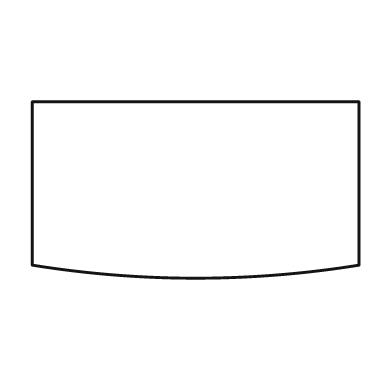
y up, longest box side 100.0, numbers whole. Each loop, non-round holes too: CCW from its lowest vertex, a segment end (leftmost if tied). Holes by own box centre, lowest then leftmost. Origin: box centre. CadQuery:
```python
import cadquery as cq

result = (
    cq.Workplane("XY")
    .moveTo(-50.0, -23.0)
    .threePointArc((0.0, -27.0), (50.0, -23.0))
    .lineTo(50.0, 27.0)
    .lineTo(-50.0, 27.0)
    .close()
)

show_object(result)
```